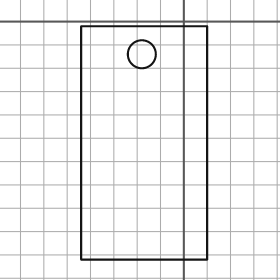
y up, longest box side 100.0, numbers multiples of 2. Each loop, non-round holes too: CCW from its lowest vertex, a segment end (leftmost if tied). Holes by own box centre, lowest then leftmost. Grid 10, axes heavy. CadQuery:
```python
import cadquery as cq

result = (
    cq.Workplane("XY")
    .moveTo(-44.0, -102.0)
    .lineTo(10.0, -102.0)
    .lineTo(10.0, -2.0)
    .lineTo(-44.0, -2.0)
    .close()
    .moveTo(-18.0, -14.0)
    .circle(6.0)
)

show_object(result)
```